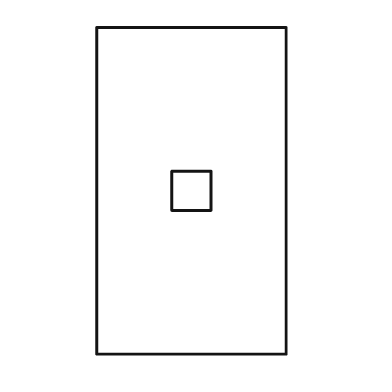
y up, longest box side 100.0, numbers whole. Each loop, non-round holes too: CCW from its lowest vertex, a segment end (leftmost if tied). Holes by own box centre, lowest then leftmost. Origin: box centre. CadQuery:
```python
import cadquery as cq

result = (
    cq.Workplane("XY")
    .moveTo(-29.0, -50.0)
    .lineTo(29.0, -50.0)
    .lineTo(29.0, 50.0)
    .lineTo(-29.0, 50.0)
    .close()
    .moveTo(-6.0, -6.0)
    .lineTo(6.0, -6.0)
    .lineTo(6.0, 6.0)
    .lineTo(-6.0, 6.0)
    .close()
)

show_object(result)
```